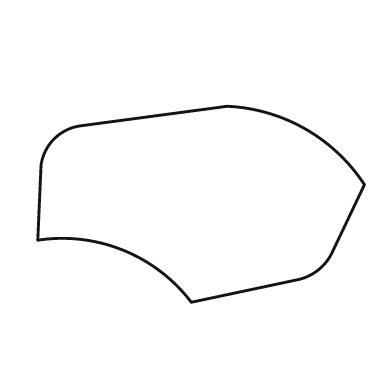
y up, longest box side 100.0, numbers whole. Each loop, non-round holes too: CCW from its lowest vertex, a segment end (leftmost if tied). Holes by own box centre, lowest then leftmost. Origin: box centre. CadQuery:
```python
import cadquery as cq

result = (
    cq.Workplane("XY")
    .moveTo(-3.0, -30.0)
    .lineTo(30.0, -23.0)
    .threePointArc((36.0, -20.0), (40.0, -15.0))
    .lineTo(50.0, 6.0)
    .threePointArc((32.0, 23.0), (8.0, 30.0))
    .lineTo(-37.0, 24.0)
    .threePointArc((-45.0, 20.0), (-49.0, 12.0))
    .lineTo(-50.0, -11.0)
    .threePointArc((-24.0, -14.0), (-3.0, -30.0))
    .close()
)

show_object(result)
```